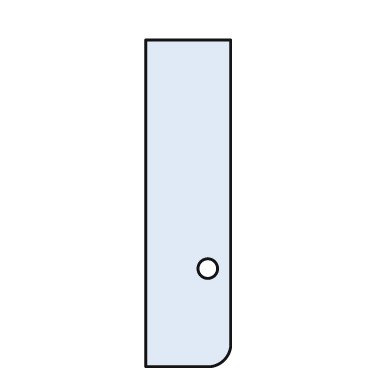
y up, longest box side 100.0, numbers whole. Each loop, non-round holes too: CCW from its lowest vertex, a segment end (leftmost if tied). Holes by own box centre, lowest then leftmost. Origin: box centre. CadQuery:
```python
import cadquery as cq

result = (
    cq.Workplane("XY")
    .moveTo(-13.0, -50.0)
    .lineTo(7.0, -50.0)
    .threePointArc((11.0, -48.0), (13.0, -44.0))
    .lineTo(13.0, 50.0)
    .lineTo(-13.0, 50.0)
    .close()
    .moveTo(6.0, -20.0)
    .circle(3.0)
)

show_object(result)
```